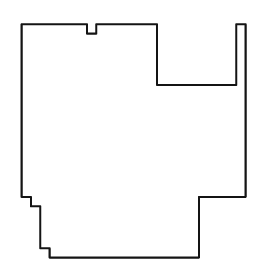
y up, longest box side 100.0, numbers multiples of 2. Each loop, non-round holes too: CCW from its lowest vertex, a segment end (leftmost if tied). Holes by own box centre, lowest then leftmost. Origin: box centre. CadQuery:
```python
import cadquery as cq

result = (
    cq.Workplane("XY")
    .moveTo(-36.0, -50.0)
    .lineTo(28.0, -50.0)
    .lineTo(28.0, -24.0)
    .lineTo(48.0, -24.0)
    .lineTo(48.0, 50.0)
    .lineTo(44.0, 50.0)
    .lineTo(44.0, 24.0)
    .lineTo(10.0, 24.0)
    .lineTo(10.0, 50.0)
    .lineTo(-16.0, 50.0)
    .lineTo(-16.0, 46.0)
    .lineTo(-20.0, 46.0)
    .lineTo(-20.0, 50.0)
    .lineTo(-48.0, 50.0)
    .lineTo(-48.0, -24.0)
    .lineTo(-44.0, -24.0)
    .lineTo(-44.0, -28.0)
    .lineTo(-40.0, -28.0)
    .lineTo(-40.0, -46.0)
    .lineTo(-36.0, -46.0)
    .close()
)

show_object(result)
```